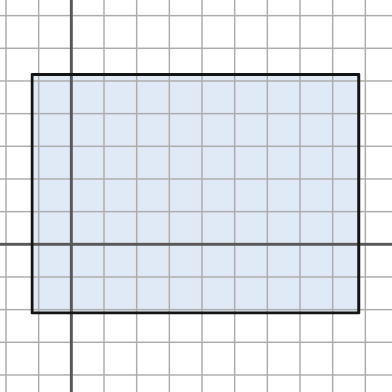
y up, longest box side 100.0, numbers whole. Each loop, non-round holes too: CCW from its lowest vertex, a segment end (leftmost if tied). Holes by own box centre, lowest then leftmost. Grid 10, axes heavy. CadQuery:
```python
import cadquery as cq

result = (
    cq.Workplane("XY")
    .moveTo(-12.0, -21.0)
    .lineTo(88.0, -21.0)
    .lineTo(88.0, 52.0)
    .lineTo(-12.0, 52.0)
    .close()
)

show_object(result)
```